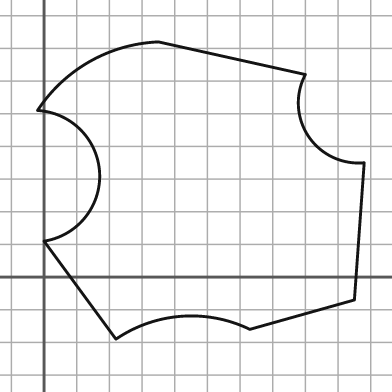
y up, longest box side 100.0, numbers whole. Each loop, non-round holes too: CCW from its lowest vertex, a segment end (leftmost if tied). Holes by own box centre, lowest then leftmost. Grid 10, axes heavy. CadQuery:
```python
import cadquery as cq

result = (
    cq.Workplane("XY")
    .moveTo(22.0, -19.0)
    .threePointArc((42.0, -12.0), (63.0, -16.0))
    .lineTo(95.0, -7.0)
    .lineTo(98.0, 35.0)
    .threePointArc((81.0, 43.0), (80.0, 62.0))
    .lineTo(35.0, 72.0)
    .threePointArc((14.0, 66.0), (-2.0, 51.0))
    .threePointArc((17.0, 32.0), (0.0, 11.0))
    .close()
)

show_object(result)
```